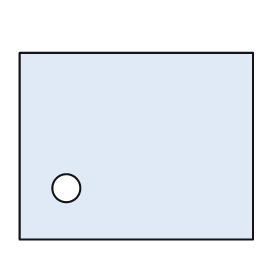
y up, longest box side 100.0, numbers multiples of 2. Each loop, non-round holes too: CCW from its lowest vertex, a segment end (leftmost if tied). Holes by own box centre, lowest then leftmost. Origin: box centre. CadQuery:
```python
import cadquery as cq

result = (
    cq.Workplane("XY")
    .moveTo(-50.0, -40.0)
    .lineTo(50.0, -40.0)
    .lineTo(50.0, 40.0)
    .lineTo(-50.0, 40.0)
    .close()
    .moveTo(-30.0, -18.0)
    .circle(6.0)
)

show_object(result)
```